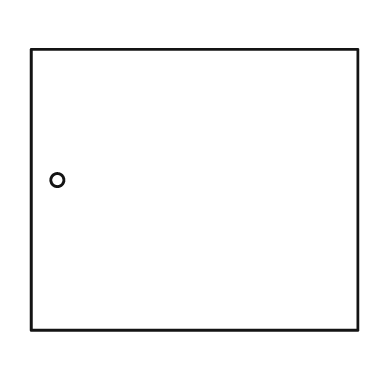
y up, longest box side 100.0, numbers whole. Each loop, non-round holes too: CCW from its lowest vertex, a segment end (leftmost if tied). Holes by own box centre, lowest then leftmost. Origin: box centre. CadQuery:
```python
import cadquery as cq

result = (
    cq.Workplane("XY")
    .moveTo(-50.0, -43.0)
    .lineTo(50.0, -43.0)
    .lineTo(50.0, 43.0)
    .lineTo(-50.0, 43.0)
    .close()
    .moveTo(-42.0, 3.0)
    .circle(2.0)
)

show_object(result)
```